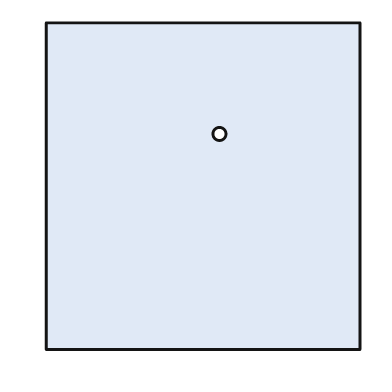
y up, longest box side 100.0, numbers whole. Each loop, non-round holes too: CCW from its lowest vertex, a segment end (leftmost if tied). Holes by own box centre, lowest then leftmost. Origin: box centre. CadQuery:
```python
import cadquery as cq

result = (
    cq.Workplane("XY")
    .moveTo(-48.0, -50.0)
    .lineTo(48.0, -50.0)
    .lineTo(48.0, 50.0)
    .lineTo(-48.0, 50.0)
    .close()
    .moveTo(5.0, 16.0)
    .circle(2.0)
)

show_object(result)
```